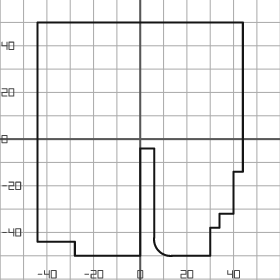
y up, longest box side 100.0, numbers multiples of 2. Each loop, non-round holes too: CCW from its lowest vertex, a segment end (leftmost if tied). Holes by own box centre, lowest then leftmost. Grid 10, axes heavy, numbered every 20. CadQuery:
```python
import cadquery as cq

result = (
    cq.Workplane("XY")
    .moveTo(-28.0, -50.0)
    .lineTo(0.0, -50.0)
    .lineTo(0.0, -4.0)
    .lineTo(6.0, -4.0)
    .lineTo(6.0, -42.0)
    .threePointArc((8.0, -48.0), (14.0, -50.0))
    .lineTo(30.0, -50.0)
    .lineTo(30.0, -38.0)
    .lineTo(34.0, -38.0)
    .lineTo(34.0, -32.0)
    .lineTo(40.0, -32.0)
    .lineTo(40.0, -14.0)
    .lineTo(44.0, -14.0)
    .lineTo(44.0, 50.0)
    .lineTo(-44.0, 50.0)
    .lineTo(-44.0, -44.0)
    .lineTo(-28.0, -44.0)
    .close()
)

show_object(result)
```